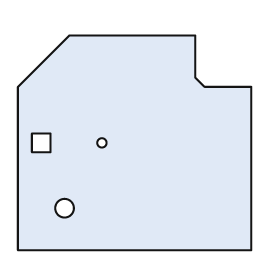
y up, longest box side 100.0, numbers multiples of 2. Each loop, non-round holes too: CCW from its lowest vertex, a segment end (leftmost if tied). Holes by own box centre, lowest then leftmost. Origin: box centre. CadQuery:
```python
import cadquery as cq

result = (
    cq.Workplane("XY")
    .moveTo(-50.0, -46.0)
    .lineTo(50.0, -46.0)
    .lineTo(50.0, 24.0)
    .lineTo(30.0, 24.0)
    .lineTo(26.0, 28.0)
    .lineTo(26.0, 46.0)
    .lineTo(-28.0, 46.0)
    .lineTo(-50.0, 24.0)
    .close()
    .moveTo(-30.0, -28.0)
    .circle(4.0)
    .moveTo(-44.0, -4.0)
    .lineTo(-36.0, -4.0)
    .lineTo(-36.0, 4.0)
    .lineTo(-44.0, 4.0)
    .close()
    .moveTo(-14.0, 0.0)
    .circle(2.0)
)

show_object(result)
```